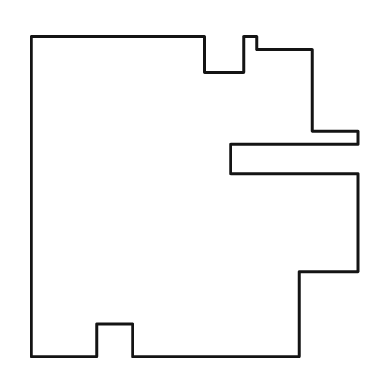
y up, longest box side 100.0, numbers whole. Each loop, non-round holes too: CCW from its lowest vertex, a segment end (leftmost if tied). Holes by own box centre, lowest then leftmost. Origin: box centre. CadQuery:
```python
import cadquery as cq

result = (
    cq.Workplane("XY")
    .moveTo(-50.0, -49.0)
    .lineTo(-30.0, -49.0)
    .lineTo(-30.0, -39.0)
    .lineTo(-19.0, -39.0)
    .lineTo(-19.0, -49.0)
    .lineTo(32.0, -49.0)
    .lineTo(32.0, -23.0)
    .lineTo(50.0, -23.0)
    .lineTo(50.0, 7.0)
    .lineTo(11.0, 7.0)
    .lineTo(11.0, 16.0)
    .lineTo(50.0, 16.0)
    .lineTo(50.0, 20.0)
    .lineTo(36.0, 20.0)
    .lineTo(36.0, 45.0)
    .lineTo(19.0, 45.0)
    .lineTo(19.0, 49.0)
    .lineTo(15.0, 49.0)
    .lineTo(15.0, 38.0)
    .lineTo(3.0, 38.0)
    .lineTo(3.0, 49.0)
    .lineTo(-50.0, 49.0)
    .close()
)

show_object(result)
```